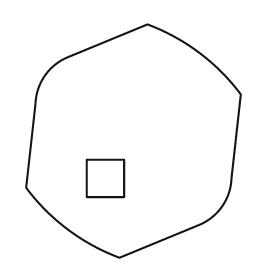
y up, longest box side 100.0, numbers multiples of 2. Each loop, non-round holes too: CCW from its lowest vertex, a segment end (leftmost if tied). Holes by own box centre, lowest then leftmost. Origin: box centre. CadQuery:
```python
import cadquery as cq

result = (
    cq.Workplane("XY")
    .moveTo(-6.0, -50.0)
    .lineTo(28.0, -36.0)
    .threePointArc((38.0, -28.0), (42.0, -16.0))
    .lineTo(46.0, 20.0)
    .threePointArc((28.0, 38.0), (6.0, 50.0))
    .lineTo(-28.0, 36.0)
    .threePointArc((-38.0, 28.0), (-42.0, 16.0))
    .lineTo(-46.0, -20.0)
    .threePointArc((-28.0, -38.0), (-6.0, -50.0))
    .close()
    .moveTo(-20.0, -24.0)
    .lineTo(-4.0, -24.0)
    .lineTo(-4.0, -8.0)
    .lineTo(-20.0, -8.0)
    .close()
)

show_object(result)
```